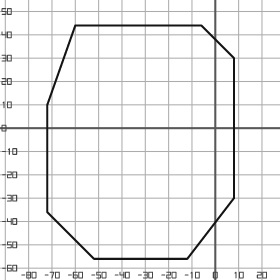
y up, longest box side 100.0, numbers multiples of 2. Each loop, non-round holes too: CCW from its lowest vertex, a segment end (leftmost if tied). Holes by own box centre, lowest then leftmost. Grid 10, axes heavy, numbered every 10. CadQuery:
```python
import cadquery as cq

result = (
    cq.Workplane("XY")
    .moveTo(-52.0, -56.0)
    .lineTo(-12.0, -56.0)
    .lineTo(8.0, -30.0)
    .lineTo(8.0, 30.0)
    .lineTo(-6.0, 44.0)
    .lineTo(-60.0, 44.0)
    .lineTo(-72.0, 10.0)
    .lineTo(-72.0, -36.0)
    .close()
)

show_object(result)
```